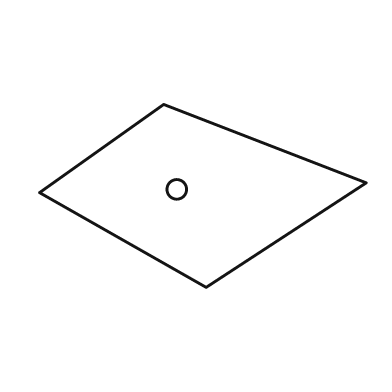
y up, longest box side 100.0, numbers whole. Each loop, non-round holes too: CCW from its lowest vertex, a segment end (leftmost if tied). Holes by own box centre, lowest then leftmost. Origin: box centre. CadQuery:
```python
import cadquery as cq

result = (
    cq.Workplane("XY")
    .moveTo(1.0, -28.0)
    .lineTo(50.0, 4.0)
    .lineTo(-12.0, 28.0)
    .lineTo(-50.0, 1.0)
    .close()
    .moveTo(-8.0, 2.0)
    .circle(3.0)
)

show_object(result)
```